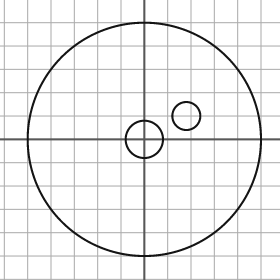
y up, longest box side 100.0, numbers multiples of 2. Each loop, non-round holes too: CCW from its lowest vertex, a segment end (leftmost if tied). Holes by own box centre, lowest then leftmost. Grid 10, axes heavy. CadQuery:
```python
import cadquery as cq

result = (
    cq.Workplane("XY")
    .moveTo(0.0, 0.0)
    .circle(50.0)
    .moveTo(0.0, 0.0)
    .circle(8.0)
    .moveTo(18.0, 10.0)
    .circle(6.0)
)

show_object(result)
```